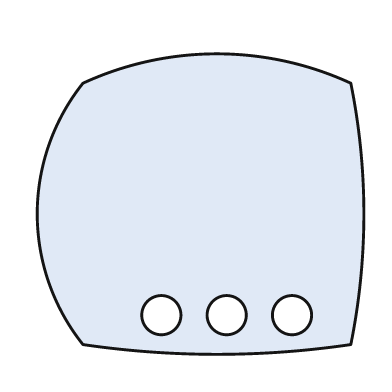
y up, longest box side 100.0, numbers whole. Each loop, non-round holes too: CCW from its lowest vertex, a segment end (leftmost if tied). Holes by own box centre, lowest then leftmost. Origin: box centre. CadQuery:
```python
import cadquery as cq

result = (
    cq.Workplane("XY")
    .moveTo(-36.0, -43.0)
    .threePointArc((5.0, -46.0), (46.0, -43.0))
    .threePointArc((50.0, -3.0), (46.0, 37.0))
    .threePointArc((5.0, 46.0), (-36.0, 37.0))
    .threePointArc((-50.0, -3.0), (-36.0, -43.0))
    .close()
    .moveTo(-12.0, -34.0)
    .circle(6.0)
    .moveTo(8.0, -34.0)
    .circle(6.0)
    .moveTo(28.0, -34.0)
    .circle(6.0)
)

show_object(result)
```